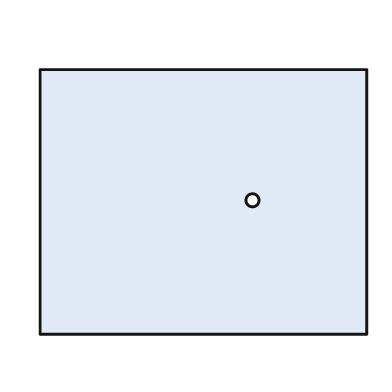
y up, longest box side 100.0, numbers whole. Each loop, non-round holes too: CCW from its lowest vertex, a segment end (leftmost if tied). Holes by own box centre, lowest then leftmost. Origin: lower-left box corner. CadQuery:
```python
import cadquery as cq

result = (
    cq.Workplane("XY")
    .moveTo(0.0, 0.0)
    .lineTo(100.0, 0.0)
    .lineTo(100.0, 81.0)
    .lineTo(0.0, 81.0)
    .close()
    .moveTo(65.0, 41.0)
    .circle(2.0)
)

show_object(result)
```